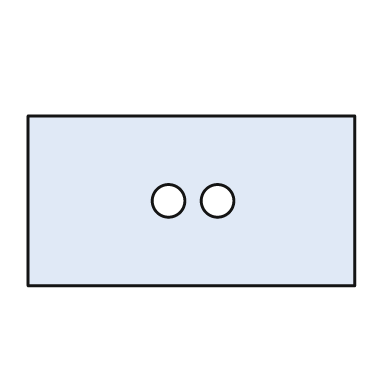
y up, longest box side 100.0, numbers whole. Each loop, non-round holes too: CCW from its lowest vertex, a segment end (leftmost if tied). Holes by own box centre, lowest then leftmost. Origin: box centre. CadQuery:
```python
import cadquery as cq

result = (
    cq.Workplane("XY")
    .moveTo(-50.0, -26.0)
    .lineTo(50.0, -26.0)
    .lineTo(50.0, 26.0)
    .lineTo(-50.0, 26.0)
    .close()
    .moveTo(-7.0, 0.0)
    .circle(5.0)
    .moveTo(8.0, 0.0)
    .circle(5.0)
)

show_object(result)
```